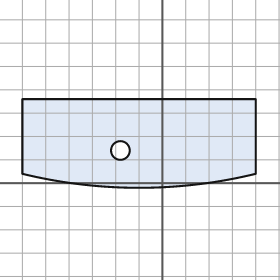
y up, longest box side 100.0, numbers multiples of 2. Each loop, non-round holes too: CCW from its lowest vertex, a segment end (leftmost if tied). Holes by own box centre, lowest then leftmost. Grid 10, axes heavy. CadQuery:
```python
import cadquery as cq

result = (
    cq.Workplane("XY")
    .moveTo(-60.0, 4.0)
    .threePointArc((-10.0, -2.0), (40.0, 4.0))
    .lineTo(40.0, 36.0)
    .lineTo(-60.0, 36.0)
    .close()
    .moveTo(-18.0, 14.0)
    .circle(4.0)
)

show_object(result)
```